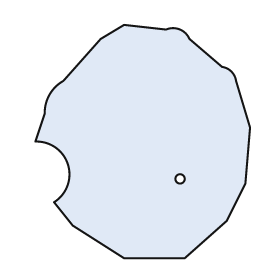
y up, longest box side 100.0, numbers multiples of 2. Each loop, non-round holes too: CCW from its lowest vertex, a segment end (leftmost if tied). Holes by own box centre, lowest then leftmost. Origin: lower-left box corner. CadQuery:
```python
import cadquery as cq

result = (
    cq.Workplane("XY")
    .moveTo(38.0, 0.0)
    .lineTo(64.0, 0.0)
    .lineTo(82.0, 16.0)
    .lineTo(90.0, 32.0)
    .lineTo(92.0, 56.0)
    .lineTo(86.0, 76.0)
    .threePointArc((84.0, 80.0), (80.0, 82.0))
    .lineTo(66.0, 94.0)
    .threePointArc((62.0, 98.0), (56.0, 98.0))
    .lineTo(38.0, 100.0)
    .lineTo(28.0, 94.0)
    .lineTo(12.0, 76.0)
    .threePointArc((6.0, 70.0), (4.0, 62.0))
    .lineTo(0.0, 50.0)
    .threePointArc((14.0, 40.0), (8.0, 24.0))
    .lineTo(16.0, 14.0)
    .close()
    .moveTo(62.0, 34.0)
    .circle(2.0)
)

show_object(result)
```